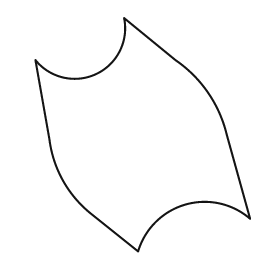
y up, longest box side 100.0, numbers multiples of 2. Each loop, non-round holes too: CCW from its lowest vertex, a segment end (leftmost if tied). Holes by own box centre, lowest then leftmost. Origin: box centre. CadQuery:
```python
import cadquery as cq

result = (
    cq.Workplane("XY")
    .moveTo(-2.0, -50.0)
    .threePointArc((18.0, -30.0), (46.0, -36.0))
    .lineTo(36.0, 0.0)
    .threePointArc((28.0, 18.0), (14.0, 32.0))
    .lineTo(-8.0, 50.0)
    .threePointArc((-20.0, 26.0), (-46.0, 32.0))
    .lineTo(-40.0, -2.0)
    .threePointArc((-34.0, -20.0), (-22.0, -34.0))
    .close()
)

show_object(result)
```